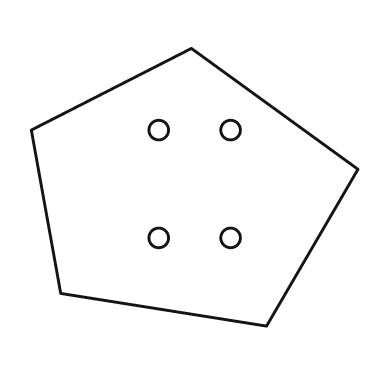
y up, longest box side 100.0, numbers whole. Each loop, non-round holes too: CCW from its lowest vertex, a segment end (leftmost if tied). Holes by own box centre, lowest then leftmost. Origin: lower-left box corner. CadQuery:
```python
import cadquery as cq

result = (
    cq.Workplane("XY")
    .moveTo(72.0, 0.0)
    .lineTo(100.0, 48.0)
    .lineTo(49.0, 85.0)
    .lineTo(0.0, 60.0)
    .lineTo(9.0, 10.0)
    .close()
    .moveTo(39.0, 27.0)
    .circle(3.0)
    .moveTo(61.0, 27.0)
    .circle(3.0)
    .moveTo(39.0, 60.0)
    .circle(3.0)
    .moveTo(61.0, 60.0)
    .circle(3.0)
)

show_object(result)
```